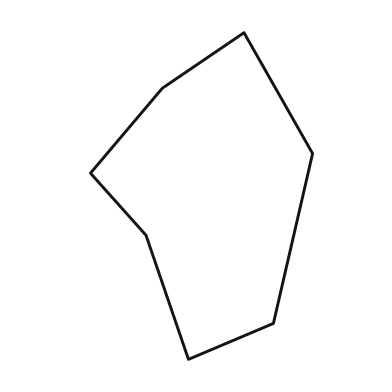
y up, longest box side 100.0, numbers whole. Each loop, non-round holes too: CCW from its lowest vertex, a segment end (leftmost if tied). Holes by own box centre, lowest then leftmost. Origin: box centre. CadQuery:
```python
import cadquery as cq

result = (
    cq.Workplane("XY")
    .moveTo(-4.0, -50.0)
    .lineTo(22.0, -39.0)
    .lineTo(34.0, 13.0)
    .lineTo(13.0, 50.0)
    .lineTo(-12.0, 33.0)
    .lineTo(-34.0, 7.0)
    .lineTo(-17.0, -12.0)
    .close()
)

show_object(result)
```